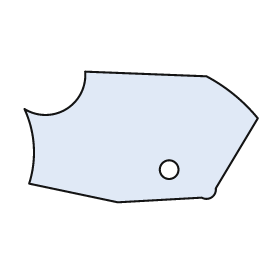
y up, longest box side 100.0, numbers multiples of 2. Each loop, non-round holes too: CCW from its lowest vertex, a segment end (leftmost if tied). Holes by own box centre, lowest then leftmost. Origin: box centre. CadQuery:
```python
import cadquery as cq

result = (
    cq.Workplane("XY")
    .moveTo(-10.0, -28.0)
    .lineTo(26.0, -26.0)
    .threePointArc((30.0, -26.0), (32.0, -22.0))
    .lineTo(50.0, 8.0)
    .threePointArc((40.0, 18.0), (28.0, 26.0))
    .lineTo(-24.0, 28.0)
    .threePointArc((-32.0, 12.0), (-50.0, 12.0))
    .threePointArc((-46.0, -4.0), (-48.0, -20.0))
    .close()
    .moveTo(12.0, -14.0)
    .circle(4.0)
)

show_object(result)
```